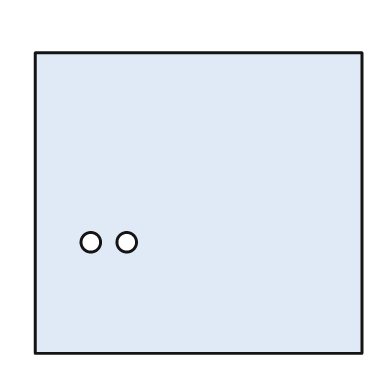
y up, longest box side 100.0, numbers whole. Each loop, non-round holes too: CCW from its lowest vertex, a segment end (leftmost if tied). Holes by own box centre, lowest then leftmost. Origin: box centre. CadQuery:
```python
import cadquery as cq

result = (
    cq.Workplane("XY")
    .moveTo(-50.0, -46.0)
    .lineTo(50.0, -46.0)
    .lineTo(50.0, 46.0)
    .lineTo(-50.0, 46.0)
    .close()
    .moveTo(-33.0, -12.0)
    .circle(3.0)
    .moveTo(-22.0, -12.0)
    .circle(3.0)
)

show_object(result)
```